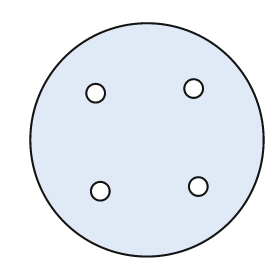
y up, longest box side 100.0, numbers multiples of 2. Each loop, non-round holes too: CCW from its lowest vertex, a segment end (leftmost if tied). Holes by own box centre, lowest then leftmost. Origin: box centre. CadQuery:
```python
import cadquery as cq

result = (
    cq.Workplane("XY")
    .moveTo(0.0, 0.0)
    .circle(50.0)
    .moveTo(-20.0, -22.0)
    .circle(4.0)
    .moveTo(22.0, -20.0)
    .circle(4.0)
    .moveTo(-22.0, 20.0)
    .circle(4.0)
    .moveTo(20.0, 22.0)
    .circle(4.0)
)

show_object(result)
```